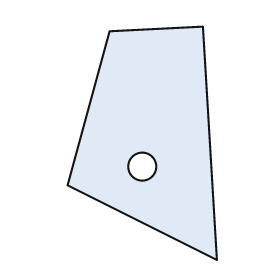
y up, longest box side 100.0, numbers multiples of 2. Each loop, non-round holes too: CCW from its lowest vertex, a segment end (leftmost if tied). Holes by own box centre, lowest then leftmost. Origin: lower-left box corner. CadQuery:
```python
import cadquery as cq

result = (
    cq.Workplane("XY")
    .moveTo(64.0, 0.0)
    .lineTo(58.0, 100.0)
    .lineTo(18.0, 98.0)
    .lineTo(0.0, 32.0)
    .close()
    .moveTo(32.0, 40.0)
    .circle(6.0)
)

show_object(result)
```